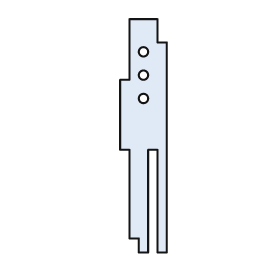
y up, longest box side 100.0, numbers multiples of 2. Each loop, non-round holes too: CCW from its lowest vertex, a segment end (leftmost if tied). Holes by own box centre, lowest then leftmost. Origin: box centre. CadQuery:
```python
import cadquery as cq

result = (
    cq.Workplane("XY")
    .moveTo(-2.0, -50.0)
    .lineTo(2.0, -50.0)
    .lineTo(2.0, -6.0)
    .lineTo(6.0, -6.0)
    .lineTo(6.0, -50.0)
    .lineTo(10.0, -50.0)
    .lineTo(10.0, 40.0)
    .lineTo(6.0, 40.0)
    .lineTo(6.0, 50.0)
    .lineTo(-6.0, 50.0)
    .lineTo(-6.0, 24.0)
    .lineTo(-10.0, 24.0)
    .lineTo(-10.0, -6.0)
    .lineTo(-6.0, -6.0)
    .lineTo(-6.0, -44.0)
    .lineTo(-2.0, -44.0)
    .close()
    .moveTo(0.0, 16.0)
    .circle(2.0)
    .moveTo(0.0, 26.0)
    .circle(2.0)
    .moveTo(0.0, 36.0)
    .circle(2.0)
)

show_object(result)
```